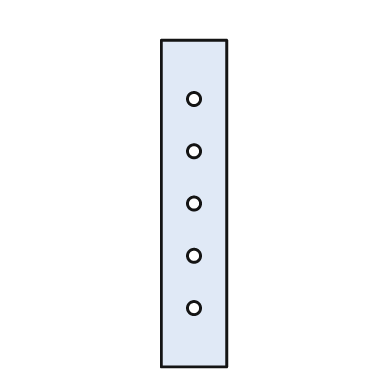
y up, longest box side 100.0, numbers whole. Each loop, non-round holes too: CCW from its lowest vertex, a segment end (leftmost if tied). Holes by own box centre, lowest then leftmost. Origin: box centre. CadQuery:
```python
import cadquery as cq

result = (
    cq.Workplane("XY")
    .moveTo(-10.0, -50.0)
    .lineTo(10.0, -50.0)
    .lineTo(10.0, 50.0)
    .lineTo(-10.0, 50.0)
    .close()
    .moveTo(0.0, -32.0)
    .circle(2.0)
    .moveTo(0.0, -16.0)
    .circle(2.0)
    .moveTo(0.0, 0.0)
    .circle(2.0)
    .moveTo(0.0, 16.0)
    .circle(2.0)
    .moveTo(0.0, 32.0)
    .circle(2.0)
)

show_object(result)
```